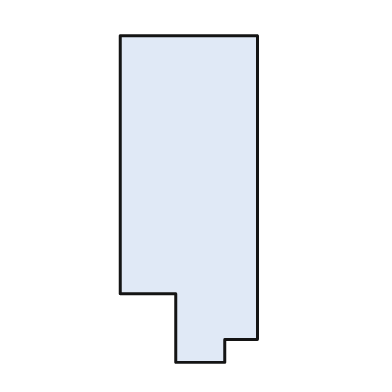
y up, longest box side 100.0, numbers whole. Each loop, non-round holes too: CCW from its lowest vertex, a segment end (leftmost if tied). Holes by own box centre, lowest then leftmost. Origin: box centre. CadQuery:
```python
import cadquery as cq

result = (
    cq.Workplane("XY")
    .moveTo(-4.0, -50.0)
    .lineTo(11.0, -50.0)
    .lineTo(11.0, -43.0)
    .lineTo(21.0, -43.0)
    .lineTo(21.0, 50.0)
    .lineTo(-21.0, 50.0)
    .lineTo(-21.0, -29.0)
    .lineTo(-4.0, -29.0)
    .close()
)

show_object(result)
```